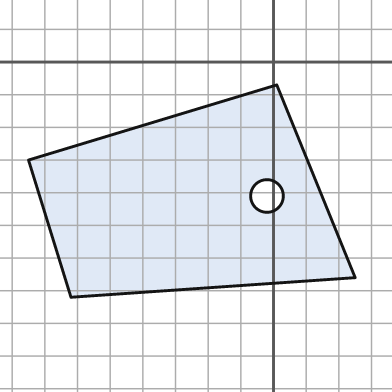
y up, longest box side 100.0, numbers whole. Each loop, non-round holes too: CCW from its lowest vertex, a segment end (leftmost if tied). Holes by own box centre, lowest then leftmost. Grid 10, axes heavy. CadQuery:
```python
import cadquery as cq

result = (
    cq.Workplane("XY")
    .moveTo(-62.0, -72.0)
    .lineTo(25.0, -66.0)
    .lineTo(1.0, -7.0)
    .lineTo(-75.0, -30.0)
    .close()
    .moveTo(-2.0, -41.0)
    .circle(5.0)
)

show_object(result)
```